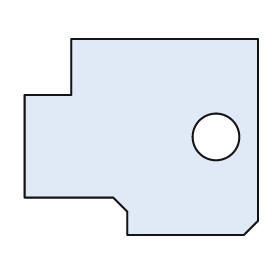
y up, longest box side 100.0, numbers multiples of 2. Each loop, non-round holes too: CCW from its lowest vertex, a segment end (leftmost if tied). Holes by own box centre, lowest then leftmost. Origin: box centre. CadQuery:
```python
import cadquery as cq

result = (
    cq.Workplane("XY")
    .moveTo(-6.0, -42.0)
    .lineTo(44.0, -42.0)
    .lineTo(50.0, -36.0)
    .lineTo(50.0, 42.0)
    .lineTo(-30.0, 42.0)
    .lineTo(-30.0, 18.0)
    .lineTo(-50.0, 18.0)
    .lineTo(-50.0, -26.0)
    .lineTo(-12.0, -26.0)
    .lineTo(-6.0, -32.0)
    .close()
    .moveTo(32.0, 0.0)
    .circle(10.0)
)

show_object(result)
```